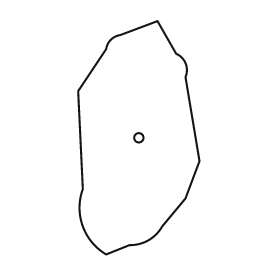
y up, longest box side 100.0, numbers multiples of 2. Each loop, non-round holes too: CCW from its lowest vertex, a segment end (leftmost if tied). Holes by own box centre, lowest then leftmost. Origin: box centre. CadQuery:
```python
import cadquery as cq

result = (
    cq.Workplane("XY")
    .moveTo(-14.0, -50.0)
    .lineTo(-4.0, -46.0)
    .threePointArc((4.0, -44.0), (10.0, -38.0))
    .lineTo(20.0, -26.0)
    .lineTo(26.0, -10.0)
    .lineTo(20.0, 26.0)
    .threePointArc((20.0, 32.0), (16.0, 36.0))
    .lineTo(8.0, 50.0)
    .lineTo(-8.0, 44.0)
    .threePointArc((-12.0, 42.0), (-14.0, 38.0))
    .lineTo(-26.0, 20.0)
    .lineTo(-24.0, -22.0)
    .threePointArc((-24.0, -38.0), (-14.0, -50.0))
    .close()
    .moveTo(0.0, 0.0)
    .circle(2.0)
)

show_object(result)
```